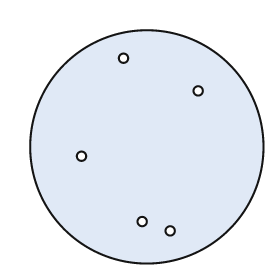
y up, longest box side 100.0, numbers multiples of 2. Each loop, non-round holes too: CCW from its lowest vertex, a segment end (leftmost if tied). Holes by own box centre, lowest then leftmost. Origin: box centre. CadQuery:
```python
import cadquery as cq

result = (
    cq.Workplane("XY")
    .moveTo(0.0, 0.0)
    .circle(50.0)
    .moveTo(10.0, -36.0)
    .circle(2.0)
    .moveTo(-2.0, -32.0)
    .circle(2.0)
    .moveTo(-28.0, -4.0)
    .circle(2.0)
    .moveTo(22.0, 24.0)
    .circle(2.0)
    .moveTo(-10.0, 38.0)
    .circle(2.0)
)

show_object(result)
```